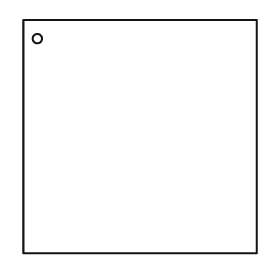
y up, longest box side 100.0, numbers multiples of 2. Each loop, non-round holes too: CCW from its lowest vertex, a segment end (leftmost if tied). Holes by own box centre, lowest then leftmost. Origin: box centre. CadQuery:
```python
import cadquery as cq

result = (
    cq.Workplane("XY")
    .moveTo(-50.0, -50.0)
    .lineTo(50.0, -50.0)
    .lineTo(50.0, 50.0)
    .lineTo(-50.0, 50.0)
    .close()
    .moveTo(-44.0, 42.0)
    .circle(2.0)
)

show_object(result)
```